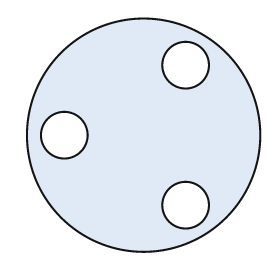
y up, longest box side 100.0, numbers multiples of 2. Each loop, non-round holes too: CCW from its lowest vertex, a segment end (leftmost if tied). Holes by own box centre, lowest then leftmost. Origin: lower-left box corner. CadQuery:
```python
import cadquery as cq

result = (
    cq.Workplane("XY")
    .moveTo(50.0, 50.0)
    .circle(50.0)
    .moveTo(68.0, 20.0)
    .circle(10.0)
    .moveTo(16.0, 50.0)
    .circle(10.0)
    .moveTo(68.0, 80.0)
    .circle(10.0)
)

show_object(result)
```